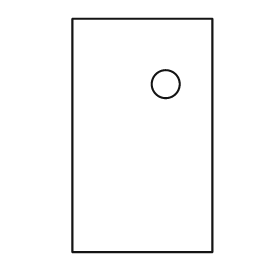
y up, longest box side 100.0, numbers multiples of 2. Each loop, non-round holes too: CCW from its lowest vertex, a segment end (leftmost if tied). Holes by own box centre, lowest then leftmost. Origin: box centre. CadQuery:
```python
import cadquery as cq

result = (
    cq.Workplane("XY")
    .moveTo(-30.0, -50.0)
    .lineTo(30.0, -50.0)
    .lineTo(30.0, 50.0)
    .lineTo(-30.0, 50.0)
    .close()
    .moveTo(10.0, 22.0)
    .circle(6.0)
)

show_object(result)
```